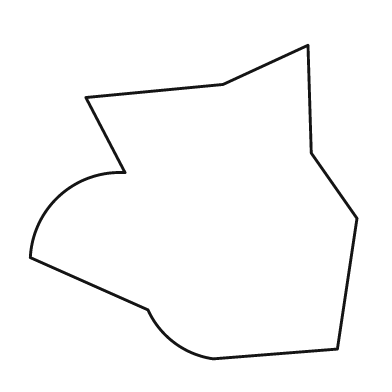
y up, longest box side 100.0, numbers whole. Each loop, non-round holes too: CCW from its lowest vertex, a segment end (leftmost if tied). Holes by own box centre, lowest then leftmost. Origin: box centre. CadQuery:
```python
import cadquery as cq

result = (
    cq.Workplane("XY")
    .moveTo(6.0, -48.0)
    .lineTo(44.0, -45.0)
    .lineTo(50.0, -5.0)
    .lineTo(36.0, 15.0)
    .lineTo(35.0, 48.0)
    .lineTo(9.0, 36.0)
    .lineTo(-33.0, 32.0)
    .lineTo(-21.0, 9.0)
    .threePointArc((-41.0, 2.0), (-50.0, -17.0))
    .lineTo(-14.0, -33.0)
    .threePointArc((-6.0, -43.0), (6.0, -48.0))
    .close()
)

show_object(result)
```